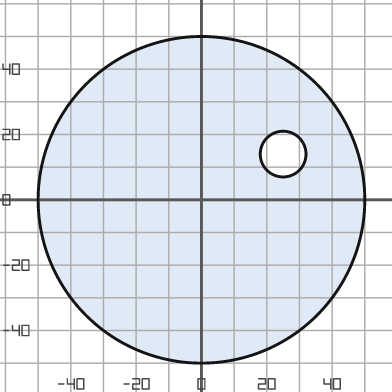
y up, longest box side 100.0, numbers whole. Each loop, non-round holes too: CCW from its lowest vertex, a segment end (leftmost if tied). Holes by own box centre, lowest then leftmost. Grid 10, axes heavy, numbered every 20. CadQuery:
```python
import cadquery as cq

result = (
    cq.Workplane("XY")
    .moveTo(0.0, 0.0)
    .circle(50.0)
    .moveTo(25.0, 14.0)
    .circle(7.0)
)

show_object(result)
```